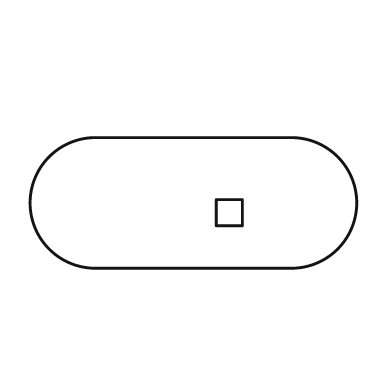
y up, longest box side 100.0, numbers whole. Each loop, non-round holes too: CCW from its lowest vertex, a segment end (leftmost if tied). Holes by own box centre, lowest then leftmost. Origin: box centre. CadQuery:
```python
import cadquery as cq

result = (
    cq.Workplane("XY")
    .moveTo(-30.0, -20.0)
    .lineTo(30.0, -20.0)
    .threePointArc((50.0, 0.0), (30.0, 20.0))
    .lineTo(-30.0, 20.0)
    .threePointArc((-50.0, 0.0), (-30.0, -20.0))
    .close()
    .moveTo(7.0, -7.0)
    .lineTo(15.0, -7.0)
    .lineTo(15.0, 1.0)
    .lineTo(7.0, 1.0)
    .close()
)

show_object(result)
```